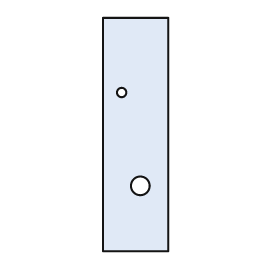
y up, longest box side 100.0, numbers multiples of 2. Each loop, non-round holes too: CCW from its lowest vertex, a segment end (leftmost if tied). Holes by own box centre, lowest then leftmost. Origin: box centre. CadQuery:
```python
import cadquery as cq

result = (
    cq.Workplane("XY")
    .moveTo(-14.0, -50.0)
    .lineTo(14.0, -50.0)
    .lineTo(14.0, 50.0)
    .lineTo(-14.0, 50.0)
    .close()
    .moveTo(2.0, -22.0)
    .circle(4.0)
    .moveTo(-6.0, 18.0)
    .circle(2.0)
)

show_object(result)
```